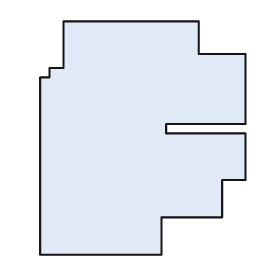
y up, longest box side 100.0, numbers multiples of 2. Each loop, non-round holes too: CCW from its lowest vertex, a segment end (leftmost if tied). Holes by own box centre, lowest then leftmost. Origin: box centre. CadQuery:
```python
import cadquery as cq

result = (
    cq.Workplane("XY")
    .moveTo(-44.0, -50.0)
    .lineTo(8.0, -50.0)
    .lineTo(8.0, -34.0)
    .lineTo(34.0, -34.0)
    .lineTo(34.0, -18.0)
    .lineTo(44.0, -18.0)
    .lineTo(44.0, 2.0)
    .lineTo(10.0, 2.0)
    .lineTo(10.0, 6.0)
    .lineTo(44.0, 6.0)
    .lineTo(44.0, 36.0)
    .lineTo(24.0, 36.0)
    .lineTo(24.0, 50.0)
    .lineTo(-34.0, 50.0)
    .lineTo(-34.0, 30.0)
    .lineTo(-40.0, 30.0)
    .lineTo(-40.0, 26.0)
    .lineTo(-44.0, 26.0)
    .close()
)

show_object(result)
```